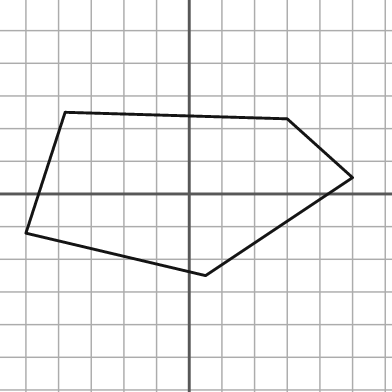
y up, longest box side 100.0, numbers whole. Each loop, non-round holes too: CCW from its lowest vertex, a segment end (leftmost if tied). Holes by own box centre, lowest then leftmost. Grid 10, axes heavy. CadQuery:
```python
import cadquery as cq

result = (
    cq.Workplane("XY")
    .moveTo(5.0, -25.0)
    .lineTo(50.0, 5.0)
    .lineTo(30.0, 23.0)
    .lineTo(-38.0, 25.0)
    .lineTo(-50.0, -12.0)
    .close()
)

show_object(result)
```